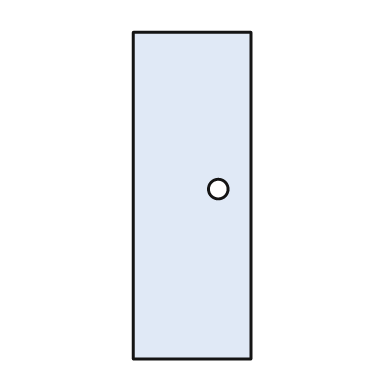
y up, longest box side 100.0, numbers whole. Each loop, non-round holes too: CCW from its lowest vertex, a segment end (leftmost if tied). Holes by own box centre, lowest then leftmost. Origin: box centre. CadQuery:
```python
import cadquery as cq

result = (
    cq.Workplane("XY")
    .moveTo(-18.0, -50.0)
    .lineTo(18.0, -50.0)
    .lineTo(18.0, 50.0)
    .lineTo(-18.0, 50.0)
    .close()
    .moveTo(8.0, 2.0)
    .circle(3.0)
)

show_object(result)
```